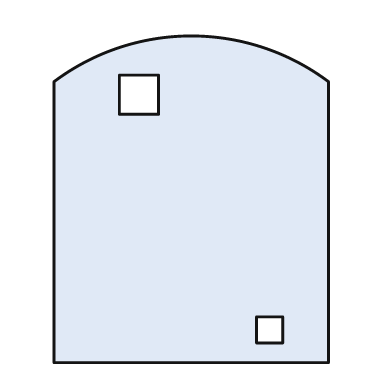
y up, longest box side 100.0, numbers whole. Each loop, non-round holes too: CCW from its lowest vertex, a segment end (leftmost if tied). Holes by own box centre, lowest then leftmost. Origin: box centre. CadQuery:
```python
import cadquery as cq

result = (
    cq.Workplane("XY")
    .moveTo(-42.0, -50.0)
    .lineTo(42.0, -50.0)
    .lineTo(42.0, 36.0)
    .threePointArc((0.0, 50.0), (-42.0, 36.0))
    .close()
    .moveTo(20.0, -44.0)
    .lineTo(28.0, -44.0)
    .lineTo(28.0, -36.0)
    .lineTo(20.0, -36.0)
    .close()
    .moveTo(-22.0, 26.0)
    .lineTo(-10.0, 26.0)
    .lineTo(-10.0, 38.0)
    .lineTo(-22.0, 38.0)
    .close()
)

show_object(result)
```